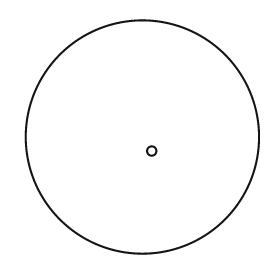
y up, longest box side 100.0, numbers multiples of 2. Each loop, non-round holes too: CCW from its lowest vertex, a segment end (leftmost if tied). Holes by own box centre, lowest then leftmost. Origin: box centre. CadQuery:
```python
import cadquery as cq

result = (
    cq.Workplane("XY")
    .moveTo(0.0, 0.0)
    .circle(50.0)
    .moveTo(4.0, -6.0)
    .circle(2.0)
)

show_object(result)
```